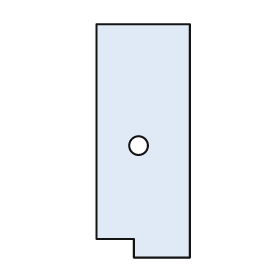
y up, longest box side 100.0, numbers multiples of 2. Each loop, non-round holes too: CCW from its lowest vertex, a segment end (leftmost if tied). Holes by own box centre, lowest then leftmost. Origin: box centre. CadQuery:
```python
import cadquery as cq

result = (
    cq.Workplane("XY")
    .moveTo(-4.0, -50.0)
    .lineTo(20.0, -50.0)
    .lineTo(20.0, 50.0)
    .lineTo(-20.0, 50.0)
    .lineTo(-20.0, -42.0)
    .lineTo(-4.0, -42.0)
    .close()
    .moveTo(-2.0, -2.0)
    .circle(4.0)
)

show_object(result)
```